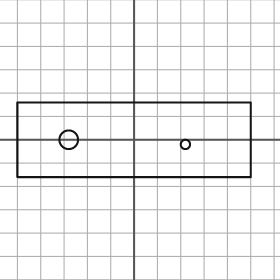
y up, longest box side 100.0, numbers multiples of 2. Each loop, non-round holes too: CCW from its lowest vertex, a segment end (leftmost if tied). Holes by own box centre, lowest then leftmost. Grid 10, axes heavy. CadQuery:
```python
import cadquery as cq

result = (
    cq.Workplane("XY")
    .moveTo(-50.0, -16.0)
    .lineTo(50.0, -16.0)
    .lineTo(50.0, 16.0)
    .lineTo(-50.0, 16.0)
    .close()
    .moveTo(22.0, -2.0)
    .circle(2.0)
    .moveTo(-28.0, 0.0)
    .circle(4.0)
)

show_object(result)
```